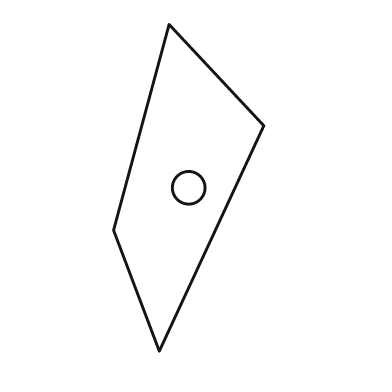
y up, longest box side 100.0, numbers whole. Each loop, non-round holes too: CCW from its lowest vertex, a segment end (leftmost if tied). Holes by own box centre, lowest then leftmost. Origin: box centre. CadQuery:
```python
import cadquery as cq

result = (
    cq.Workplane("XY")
    .moveTo(-9.0, -50.0)
    .lineTo(23.0, 19.0)
    .lineTo(-6.0, 50.0)
    .lineTo(-23.0, -13.0)
    .close()
    .moveTo(0.0, 0.0)
    .circle(5.0)
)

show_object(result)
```